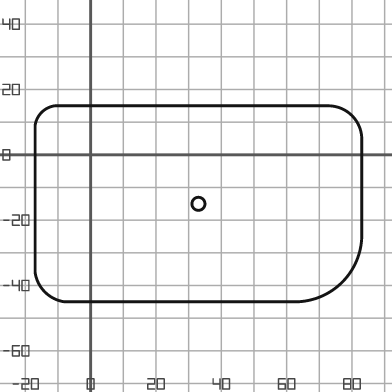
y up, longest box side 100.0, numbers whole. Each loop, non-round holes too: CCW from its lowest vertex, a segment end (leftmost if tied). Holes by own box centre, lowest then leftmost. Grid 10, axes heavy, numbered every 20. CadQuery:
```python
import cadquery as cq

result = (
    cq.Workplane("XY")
    .moveTo(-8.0, -45.0)
    .lineTo(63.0, -45.0)
    .threePointArc((77.0, -39.0), (83.0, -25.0))
    .lineTo(83.0, 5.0)
    .threePointArc((80.0, 12.0), (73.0, 15.0))
    .lineTo(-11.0, 15.0)
    .threePointArc((-15.0, 13.0), (-17.0, 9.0))
    .lineTo(-17.0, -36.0)
    .threePointArc((-14.0, -42.0), (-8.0, -45.0))
    .close()
    .moveTo(33.0, -15.0)
    .circle(2.0)
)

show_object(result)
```